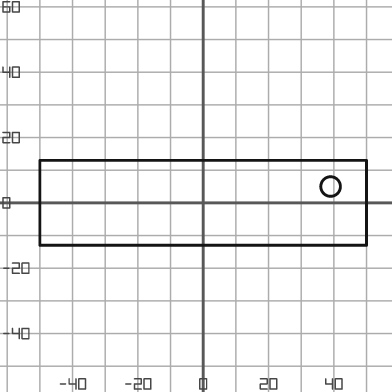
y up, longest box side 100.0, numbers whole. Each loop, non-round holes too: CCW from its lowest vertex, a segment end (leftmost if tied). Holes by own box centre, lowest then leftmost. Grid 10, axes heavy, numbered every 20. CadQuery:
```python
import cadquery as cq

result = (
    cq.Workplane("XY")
    .moveTo(-50.0, -13.0)
    .lineTo(50.0, -13.0)
    .lineTo(50.0, 13.0)
    .lineTo(-50.0, 13.0)
    .close()
    .moveTo(39.0, 5.0)
    .circle(3.0)
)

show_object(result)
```